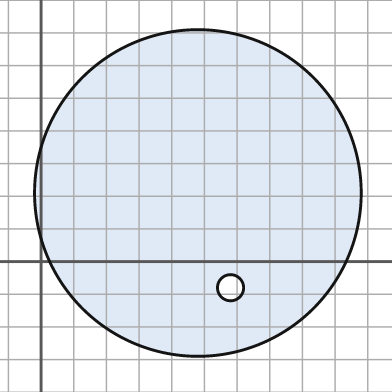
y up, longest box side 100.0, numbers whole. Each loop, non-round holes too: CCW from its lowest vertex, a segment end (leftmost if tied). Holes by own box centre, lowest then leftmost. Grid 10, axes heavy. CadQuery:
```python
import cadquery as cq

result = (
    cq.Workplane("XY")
    .moveTo(48.0, 21.0)
    .circle(50.0)
    .moveTo(58.0, -8.0)
    .circle(4.0)
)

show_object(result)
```